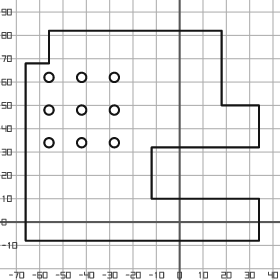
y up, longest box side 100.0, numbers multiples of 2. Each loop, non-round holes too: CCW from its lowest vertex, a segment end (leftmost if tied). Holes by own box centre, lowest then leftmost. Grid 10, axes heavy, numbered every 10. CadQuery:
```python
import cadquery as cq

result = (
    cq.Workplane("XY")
    .moveTo(-66.0, -8.0)
    .lineTo(34.0, -8.0)
    .lineTo(34.0, 10.0)
    .lineTo(-12.0, 10.0)
    .lineTo(-12.0, 32.0)
    .lineTo(34.0, 32.0)
    .lineTo(34.0, 50.0)
    .lineTo(18.0, 50.0)
    .lineTo(18.0, 82.0)
    .lineTo(-56.0, 82.0)
    .lineTo(-56.0, 68.0)
    .lineTo(-66.0, 68.0)
    .close()
    .moveTo(-56.0, 34.0)
    .circle(2.0)
    .moveTo(-42.0, 34.0)
    .circle(2.0)
    .moveTo(-28.0, 34.0)
    .circle(2.0)
    .moveTo(-56.0, 48.0)
    .circle(2.0)
    .moveTo(-42.0, 48.0)
    .circle(2.0)
    .moveTo(-28.0, 48.0)
    .circle(2.0)
    .moveTo(-56.0, 62.0)
    .circle(2.0)
    .moveTo(-42.0, 62.0)
    .circle(2.0)
    .moveTo(-28.0, 62.0)
    .circle(2.0)
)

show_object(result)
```